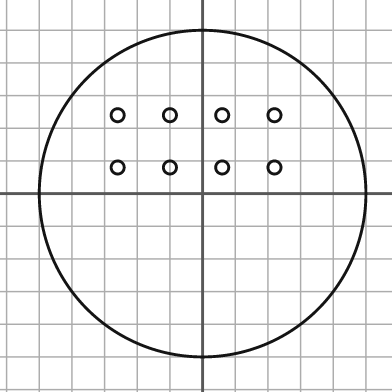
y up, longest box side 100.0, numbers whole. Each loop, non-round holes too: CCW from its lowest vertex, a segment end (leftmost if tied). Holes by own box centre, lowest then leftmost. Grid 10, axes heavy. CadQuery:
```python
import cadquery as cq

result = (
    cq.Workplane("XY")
    .moveTo(0.0, 0.0)
    .circle(50.0)
    .moveTo(-26.0, 8.0)
    .circle(2.0)
    .moveTo(-10.0, 8.0)
    .circle(2.0)
    .moveTo(6.0, 8.0)
    .circle(2.0)
    .moveTo(22.0, 8.0)
    .circle(2.0)
    .moveTo(-26.0, 24.0)
    .circle(2.0)
    .moveTo(-10.0, 24.0)
    .circle(2.0)
    .moveTo(6.0, 24.0)
    .circle(2.0)
    .moveTo(22.0, 24.0)
    .circle(2.0)
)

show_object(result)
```